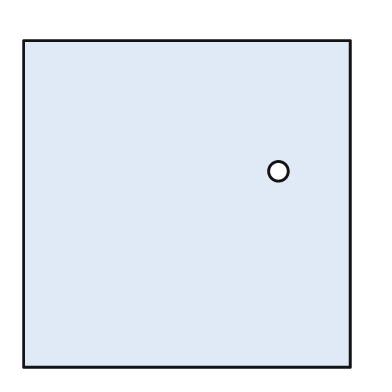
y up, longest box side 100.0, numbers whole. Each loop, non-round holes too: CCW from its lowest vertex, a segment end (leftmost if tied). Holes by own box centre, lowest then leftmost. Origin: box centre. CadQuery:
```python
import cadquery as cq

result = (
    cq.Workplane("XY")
    .moveTo(-50.0, -50.0)
    .lineTo(50.0, -50.0)
    .lineTo(50.0, 50.0)
    .lineTo(-50.0, 50.0)
    .close()
    .moveTo(28.0, 10.0)
    .circle(3.0)
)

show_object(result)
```